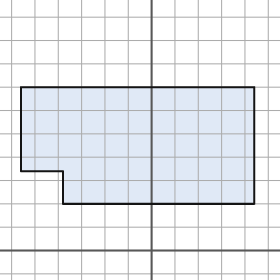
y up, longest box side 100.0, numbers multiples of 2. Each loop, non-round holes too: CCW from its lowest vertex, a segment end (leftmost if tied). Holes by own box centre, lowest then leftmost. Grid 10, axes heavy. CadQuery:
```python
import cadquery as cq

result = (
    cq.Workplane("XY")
    .moveTo(-38.0, 20.0)
    .lineTo(44.0, 20.0)
    .lineTo(44.0, 70.0)
    .lineTo(-56.0, 70.0)
    .lineTo(-56.0, 34.0)
    .lineTo(-38.0, 34.0)
    .close()
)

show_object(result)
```